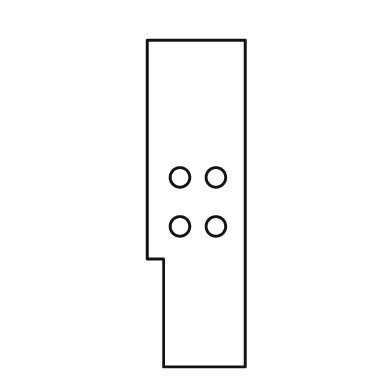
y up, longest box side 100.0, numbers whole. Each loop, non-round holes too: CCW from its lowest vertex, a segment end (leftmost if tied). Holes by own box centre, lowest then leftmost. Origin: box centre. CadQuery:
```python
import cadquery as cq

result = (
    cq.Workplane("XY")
    .moveTo(-10.0, -50.0)
    .lineTo(15.0, -50.0)
    .lineTo(15.0, 50.0)
    .lineTo(-15.0, 50.0)
    .lineTo(-15.0, -17.0)
    .lineTo(-10.0, -17.0)
    .close()
    .moveTo(-5.0, -7.0)
    .circle(3.0)
    .moveTo(6.0, -7.0)
    .circle(3.0)
    .moveTo(-5.0, 8.0)
    .circle(3.0)
    .moveTo(6.0, 8.0)
    .circle(3.0)
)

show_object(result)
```